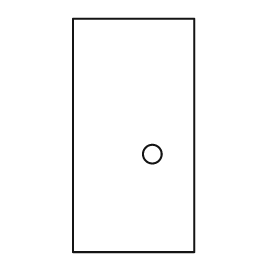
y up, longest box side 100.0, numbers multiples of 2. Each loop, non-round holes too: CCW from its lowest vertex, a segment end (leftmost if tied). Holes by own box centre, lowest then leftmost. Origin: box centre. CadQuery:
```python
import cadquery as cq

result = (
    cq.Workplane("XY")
    .moveTo(-26.0, -50.0)
    .lineTo(26.0, -50.0)
    .lineTo(26.0, 50.0)
    .lineTo(-26.0, 50.0)
    .close()
    .moveTo(8.0, -8.0)
    .circle(4.0)
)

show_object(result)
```